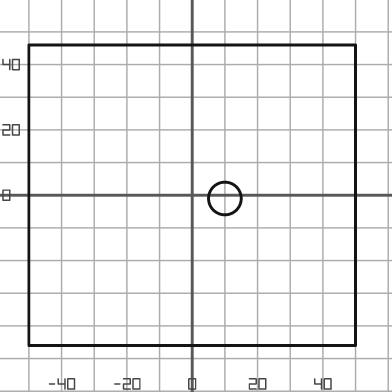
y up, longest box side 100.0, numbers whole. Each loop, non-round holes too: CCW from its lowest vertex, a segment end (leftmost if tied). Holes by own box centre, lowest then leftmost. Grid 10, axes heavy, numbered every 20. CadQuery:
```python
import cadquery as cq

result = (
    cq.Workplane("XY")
    .moveTo(-50.0, -46.0)
    .lineTo(50.0, -46.0)
    .lineTo(50.0, 46.0)
    .lineTo(-50.0, 46.0)
    .close()
    .moveTo(10.0, -1.0)
    .circle(5.0)
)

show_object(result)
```